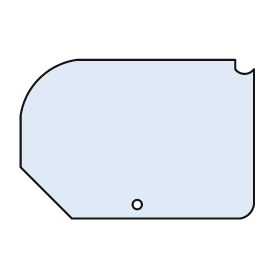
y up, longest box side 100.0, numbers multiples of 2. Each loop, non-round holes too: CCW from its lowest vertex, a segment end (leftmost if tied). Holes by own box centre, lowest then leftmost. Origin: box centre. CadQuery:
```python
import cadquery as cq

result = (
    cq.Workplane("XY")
    .moveTo(-28.0, -34.0)
    .lineTo(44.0, -34.0)
    .threePointArc((48.0, -32.0), (50.0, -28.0))
    .lineTo(50.0, 30.0)
    .threePointArc((46.0, 28.0), (42.0, 30.0))
    .lineTo(42.0, 34.0)
    .lineTo(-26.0, 34.0)
    .threePointArc((-42.0, 26.0), (-50.0, 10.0))
    .lineTo(-50.0, -12.0)
    .close()
    .moveTo(0.0, -28.0)
    .circle(2.0)
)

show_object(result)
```